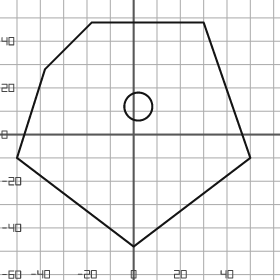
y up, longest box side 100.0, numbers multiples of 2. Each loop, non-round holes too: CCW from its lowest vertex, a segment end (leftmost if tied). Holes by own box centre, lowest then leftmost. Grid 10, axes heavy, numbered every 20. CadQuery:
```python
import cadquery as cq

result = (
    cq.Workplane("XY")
    .moveTo(0.0, -48.0)
    .lineTo(50.0, -10.0)
    .lineTo(30.0, 48.0)
    .lineTo(-18.0, 48.0)
    .lineTo(-38.0, 28.0)
    .lineTo(-50.0, -10.0)
    .close()
    .moveTo(2.0, 12.0)
    .circle(6.0)
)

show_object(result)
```